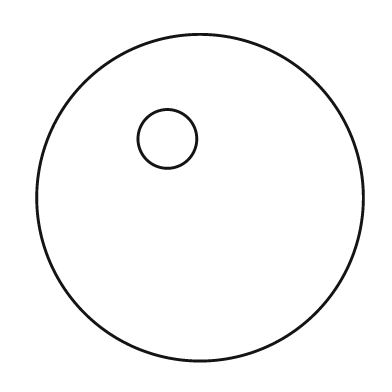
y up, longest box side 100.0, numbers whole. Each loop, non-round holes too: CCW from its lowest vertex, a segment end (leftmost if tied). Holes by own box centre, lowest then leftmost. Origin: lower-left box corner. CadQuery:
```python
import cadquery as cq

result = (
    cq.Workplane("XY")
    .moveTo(50.0, 50.0)
    .circle(50.0)
    .moveTo(40.0, 68.0)
    .circle(9.0)
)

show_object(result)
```